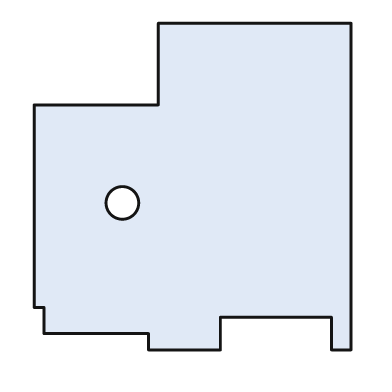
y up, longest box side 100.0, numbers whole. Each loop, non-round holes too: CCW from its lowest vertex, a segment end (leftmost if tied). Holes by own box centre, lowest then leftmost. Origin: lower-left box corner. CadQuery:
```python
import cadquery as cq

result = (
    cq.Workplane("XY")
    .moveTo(35.0, 0.0)
    .lineTo(57.0, 0.0)
    .lineTo(57.0, 10.0)
    .lineTo(91.0, 10.0)
    .lineTo(91.0, 0.0)
    .lineTo(97.0, 0.0)
    .lineTo(97.0, 100.0)
    .lineTo(38.0, 100.0)
    .lineTo(38.0, 75.0)
    .lineTo(0.0, 75.0)
    .lineTo(0.0, 13.0)
    .lineTo(3.0, 13.0)
    .lineTo(3.0, 5.0)
    .lineTo(35.0, 5.0)
    .close()
    .moveTo(27.0, 45.0)
    .circle(5.0)
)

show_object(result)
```